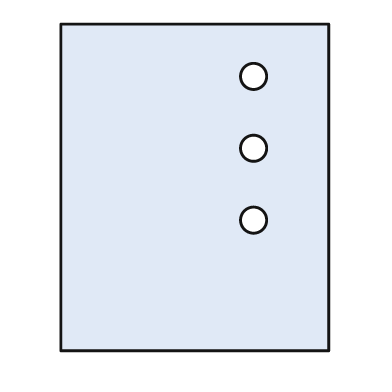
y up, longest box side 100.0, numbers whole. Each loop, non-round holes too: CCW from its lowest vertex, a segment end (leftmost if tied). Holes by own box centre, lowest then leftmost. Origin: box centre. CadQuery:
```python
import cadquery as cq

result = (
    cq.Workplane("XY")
    .moveTo(-41.0, -50.0)
    .lineTo(41.0, -50.0)
    .lineTo(41.0, 50.0)
    .lineTo(-41.0, 50.0)
    .close()
    .moveTo(18.0, -10.0)
    .circle(4.0)
    .moveTo(18.0, 12.0)
    .circle(4.0)
    .moveTo(18.0, 34.0)
    .circle(4.0)
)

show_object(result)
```